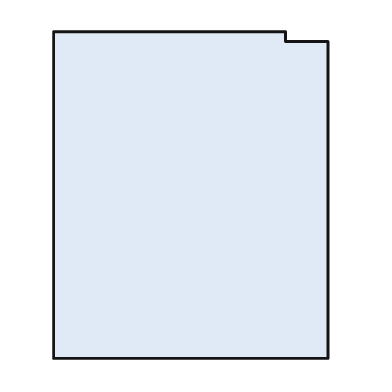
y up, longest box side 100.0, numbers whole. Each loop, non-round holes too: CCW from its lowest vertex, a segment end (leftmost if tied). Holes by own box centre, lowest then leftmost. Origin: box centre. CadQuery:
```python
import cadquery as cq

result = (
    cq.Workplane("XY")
    .moveTo(-42.0, -50.0)
    .lineTo(42.0, -50.0)
    .lineTo(42.0, 47.0)
    .lineTo(29.0, 47.0)
    .lineTo(29.0, 50.0)
    .lineTo(-42.0, 50.0)
    .close()
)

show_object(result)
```